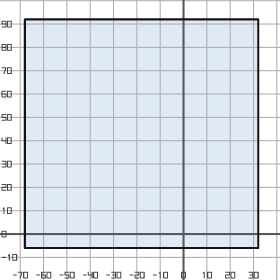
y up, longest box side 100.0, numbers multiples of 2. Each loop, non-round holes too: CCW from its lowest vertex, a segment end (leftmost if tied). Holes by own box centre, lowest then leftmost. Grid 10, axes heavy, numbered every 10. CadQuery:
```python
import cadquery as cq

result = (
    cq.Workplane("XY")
    .moveTo(-68.0, -6.0)
    .lineTo(32.0, -6.0)
    .lineTo(32.0, 92.0)
    .lineTo(-68.0, 92.0)
    .close()
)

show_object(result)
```